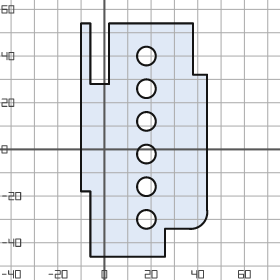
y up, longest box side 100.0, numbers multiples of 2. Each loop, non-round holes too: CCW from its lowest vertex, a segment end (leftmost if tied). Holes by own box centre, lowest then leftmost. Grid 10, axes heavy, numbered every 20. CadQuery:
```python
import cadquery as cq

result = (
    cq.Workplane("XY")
    .moveTo(-6.0, -46.0)
    .lineTo(26.0, -46.0)
    .lineTo(26.0, -34.0)
    .lineTo(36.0, -34.0)
    .threePointArc((42.0, -32.0), (44.0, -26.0))
    .lineTo(44.0, 32.0)
    .lineTo(38.0, 32.0)
    .lineTo(38.0, 54.0)
    .lineTo(2.0, 54.0)
    .lineTo(2.0, 28.0)
    .lineTo(-6.0, 28.0)
    .lineTo(-6.0, 54.0)
    .lineTo(-10.0, 54.0)
    .lineTo(-10.0, -18.0)
    .lineTo(-6.0, -18.0)
    .close()
    .moveTo(18.0, -30.0)
    .circle(4.0)
    .moveTo(18.0, -16.0)
    .circle(4.0)
    .moveTo(18.0, -2.0)
    .circle(4.0)
    .moveTo(18.0, 12.0)
    .circle(4.0)
    .moveTo(18.0, 26.0)
    .circle(4.0)
    .moveTo(18.0, 40.0)
    .circle(4.0)
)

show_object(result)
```